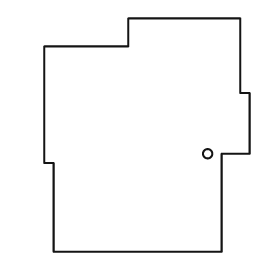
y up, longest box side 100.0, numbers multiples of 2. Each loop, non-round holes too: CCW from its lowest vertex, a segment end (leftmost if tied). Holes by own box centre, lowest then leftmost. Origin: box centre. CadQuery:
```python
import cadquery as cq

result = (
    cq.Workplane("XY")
    .moveTo(-40.0, -50.0)
    .lineTo(32.0, -50.0)
    .lineTo(32.0, -8.0)
    .lineTo(44.0, -8.0)
    .lineTo(44.0, 18.0)
    .lineTo(40.0, 18.0)
    .lineTo(40.0, 50.0)
    .lineTo(-8.0, 50.0)
    .lineTo(-8.0, 38.0)
    .lineTo(-44.0, 38.0)
    .lineTo(-44.0, -12.0)
    .lineTo(-40.0, -12.0)
    .close()
    .moveTo(26.0, -8.0)
    .circle(2.0)
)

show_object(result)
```